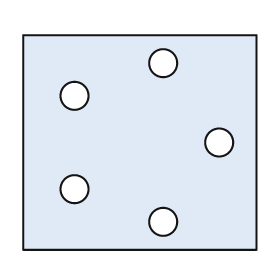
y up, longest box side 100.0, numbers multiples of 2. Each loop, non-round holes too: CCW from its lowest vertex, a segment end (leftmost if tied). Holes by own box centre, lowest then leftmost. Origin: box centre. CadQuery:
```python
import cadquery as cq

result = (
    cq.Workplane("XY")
    .moveTo(-50.0, -46.0)
    .lineTo(50.0, -46.0)
    .lineTo(50.0, 46.0)
    .lineTo(-50.0, 46.0)
    .close()
    .moveTo(10.0, -34.0)
    .circle(6.0)
    .moveTo(-28.0, -20.0)
    .circle(6.0)
    .moveTo(34.0, 0.0)
    .circle(6.0)
    .moveTo(-28.0, 20.0)
    .circle(6.0)
    .moveTo(10.0, 34.0)
    .circle(6.0)
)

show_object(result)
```